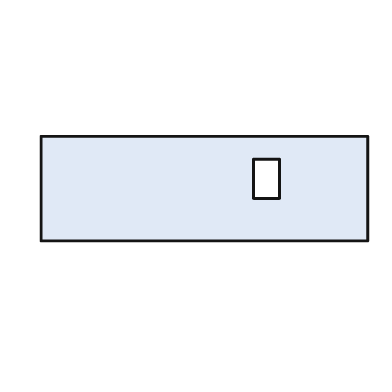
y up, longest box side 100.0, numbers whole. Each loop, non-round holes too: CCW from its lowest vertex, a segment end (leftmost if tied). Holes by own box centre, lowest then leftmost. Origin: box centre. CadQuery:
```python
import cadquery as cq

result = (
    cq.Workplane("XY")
    .moveTo(-50.0, -16.0)
    .lineTo(50.0, -16.0)
    .lineTo(50.0, 16.0)
    .lineTo(-50.0, 16.0)
    .close()
    .moveTo(15.0, -3.0)
    .lineTo(23.0, -3.0)
    .lineTo(23.0, 9.0)
    .lineTo(15.0, 9.0)
    .close()
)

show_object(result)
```